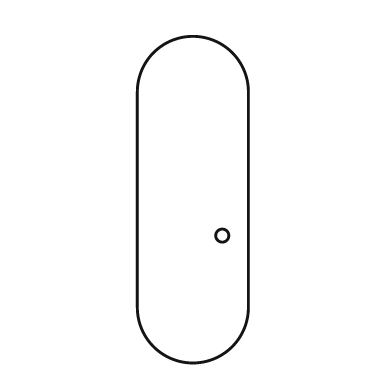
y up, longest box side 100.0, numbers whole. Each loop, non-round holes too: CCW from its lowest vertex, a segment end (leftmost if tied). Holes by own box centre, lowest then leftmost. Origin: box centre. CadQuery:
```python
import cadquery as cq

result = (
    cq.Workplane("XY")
    .moveTo(-17.0, -33.0)
    .threePointArc((0.0, -50.0), (17.0, -33.0))
    .lineTo(17.0, 33.0)
    .threePointArc((0.0, 50.0), (-17.0, 33.0))
    .close()
    .moveTo(9.0, -11.0)
    .circle(2.0)
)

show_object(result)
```